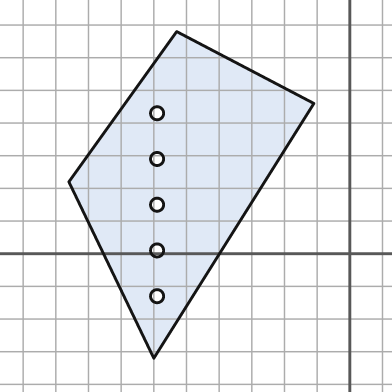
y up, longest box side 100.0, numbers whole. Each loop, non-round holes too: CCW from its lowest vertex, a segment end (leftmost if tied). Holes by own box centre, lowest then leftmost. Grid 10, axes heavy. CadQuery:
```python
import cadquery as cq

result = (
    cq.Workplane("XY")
    .moveTo(-60.0, -32.0)
    .lineTo(-11.0, 46.0)
    .lineTo(-53.0, 68.0)
    .lineTo(-86.0, 22.0)
    .close()
    .moveTo(-59.0, -13.0)
    .circle(2.0)
    .moveTo(-59.0, 1.0)
    .circle(2.0)
    .moveTo(-59.0, 15.0)
    .circle(2.0)
    .moveTo(-59.0, 29.0)
    .circle(2.0)
    .moveTo(-59.0, 43.0)
    .circle(2.0)
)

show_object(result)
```